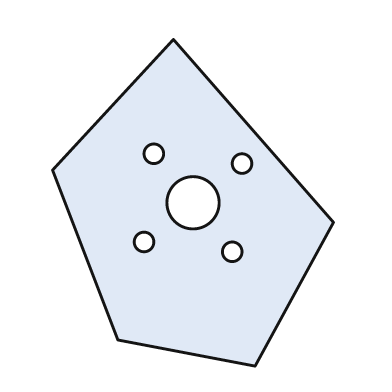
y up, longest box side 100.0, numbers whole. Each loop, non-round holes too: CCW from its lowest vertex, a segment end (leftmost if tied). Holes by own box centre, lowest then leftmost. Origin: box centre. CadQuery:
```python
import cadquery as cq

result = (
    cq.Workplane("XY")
    .moveTo(19.0, -50.0)
    .lineTo(43.0, -6.0)
    .lineTo(-6.0, 50.0)
    .lineTo(-43.0, 10.0)
    .lineTo(-23.0, -42.0)
    .close()
    .moveTo(12.0, -15.0)
    .circle(3.0)
    .moveTo(-15.0, -12.0)
    .circle(3.0)
    .moveTo(0.0, 0.0)
    .circle(8.0)
    .moveTo(15.0, 12.0)
    .circle(3.0)
    .moveTo(-12.0, 15.0)
    .circle(3.0)
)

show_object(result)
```